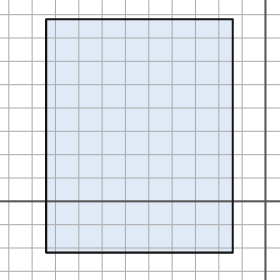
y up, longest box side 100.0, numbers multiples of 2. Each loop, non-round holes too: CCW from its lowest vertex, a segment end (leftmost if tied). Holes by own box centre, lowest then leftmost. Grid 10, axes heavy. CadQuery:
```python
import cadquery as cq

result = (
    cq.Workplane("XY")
    .moveTo(-94.0, -22.0)
    .lineTo(-14.0, -22.0)
    .lineTo(-14.0, 78.0)
    .lineTo(-94.0, 78.0)
    .close()
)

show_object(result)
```